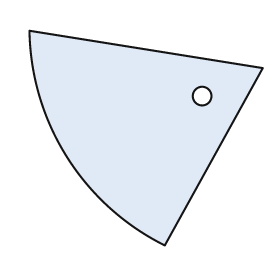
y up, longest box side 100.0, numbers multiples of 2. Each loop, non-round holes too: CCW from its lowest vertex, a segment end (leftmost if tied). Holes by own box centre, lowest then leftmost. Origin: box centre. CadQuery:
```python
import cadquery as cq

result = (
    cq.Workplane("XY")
    .moveTo(8.0, -46.0)
    .lineTo(50.0, 30.0)
    .lineTo(-50.0, 46.0)
    .threePointArc((-34.0, -8.0), (8.0, -46.0))
    .close()
    .moveTo(24.0, 18.0)
    .circle(4.0)
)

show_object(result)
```